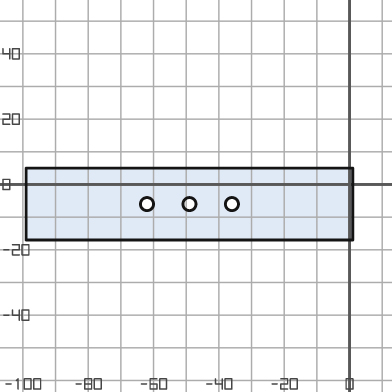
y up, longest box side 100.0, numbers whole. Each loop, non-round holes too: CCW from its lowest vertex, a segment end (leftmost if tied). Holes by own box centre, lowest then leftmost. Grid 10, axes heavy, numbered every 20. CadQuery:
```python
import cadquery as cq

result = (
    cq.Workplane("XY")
    .moveTo(-99.0, -17.0)
    .lineTo(1.0, -17.0)
    .lineTo(1.0, 5.0)
    .lineTo(-99.0, 5.0)
    .close()
    .moveTo(-62.0, -6.0)
    .circle(2.0)
    .moveTo(-49.0, -6.0)
    .circle(2.0)
    .moveTo(-36.0, -6.0)
    .circle(2.0)
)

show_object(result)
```